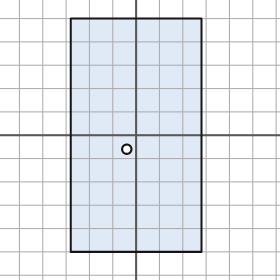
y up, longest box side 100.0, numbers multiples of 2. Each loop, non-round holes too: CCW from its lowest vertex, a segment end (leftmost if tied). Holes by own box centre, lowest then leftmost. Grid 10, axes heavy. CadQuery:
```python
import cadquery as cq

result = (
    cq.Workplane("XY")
    .moveTo(-28.0, -50.0)
    .lineTo(28.0, -50.0)
    .lineTo(28.0, 50.0)
    .lineTo(-28.0, 50.0)
    .close()
    .moveTo(-4.0, -6.0)
    .circle(2.0)
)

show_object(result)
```